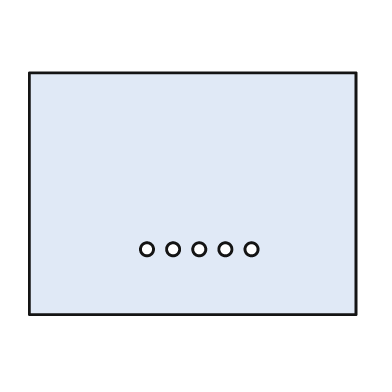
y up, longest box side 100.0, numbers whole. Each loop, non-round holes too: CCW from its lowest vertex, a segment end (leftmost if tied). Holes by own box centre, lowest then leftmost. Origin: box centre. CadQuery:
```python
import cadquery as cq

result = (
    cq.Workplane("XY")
    .moveTo(-50.0, -37.0)
    .lineTo(50.0, -37.0)
    .lineTo(50.0, 37.0)
    .lineTo(-50.0, 37.0)
    .close()
    .moveTo(-14.0, -17.0)
    .circle(2.0)
    .moveTo(-6.0, -17.0)
    .circle(2.0)
    .moveTo(2.0, -17.0)
    .circle(2.0)
    .moveTo(10.0, -17.0)
    .circle(2.0)
    .moveTo(18.0, -17.0)
    .circle(2.0)
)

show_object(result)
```